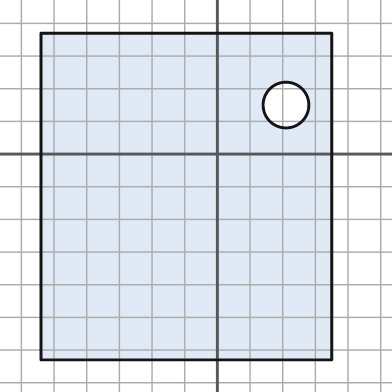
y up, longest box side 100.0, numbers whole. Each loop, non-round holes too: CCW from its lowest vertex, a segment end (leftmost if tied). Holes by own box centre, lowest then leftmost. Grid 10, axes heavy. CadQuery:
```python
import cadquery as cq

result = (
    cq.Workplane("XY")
    .moveTo(-54.0, -63.0)
    .lineTo(35.0, -63.0)
    .lineTo(35.0, 37.0)
    .lineTo(-54.0, 37.0)
    .close()
    .moveTo(21.0, 15.0)
    .circle(7.0)
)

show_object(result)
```